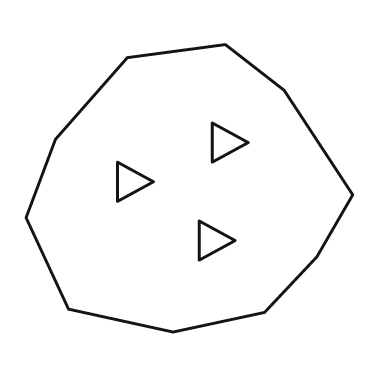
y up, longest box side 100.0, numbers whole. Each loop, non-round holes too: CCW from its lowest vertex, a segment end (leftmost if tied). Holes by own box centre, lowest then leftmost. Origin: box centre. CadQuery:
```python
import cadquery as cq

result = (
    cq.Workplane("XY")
    .moveTo(-5.0, -44.0)
    .lineTo(23.0, -38.0)
    .lineTo(39.0, -21.0)
    .lineTo(50.0, -2.0)
    .lineTo(29.0, 30.0)
    .lineTo(11.0, 44.0)
    .lineTo(-19.0, 40.0)
    .lineTo(-41.0, 15.0)
    .lineTo(-50.0, -9.0)
    .lineTo(-37.0, -37.0)
    .close()
    .moveTo(3.0, -22.0)
    .lineTo(14.0, -16.0)
    .lineTo(3.0, -10.0)
    .close()
    .moveTo(-22.0, -4.0)
    .lineTo(-11.0, 2.0)
    .lineTo(-22.0, 8.0)
    .close()
    .moveTo(7.0, 8.0)
    .lineTo(18.0, 14.0)
    .lineTo(7.0, 20.0)
    .close()
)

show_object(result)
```